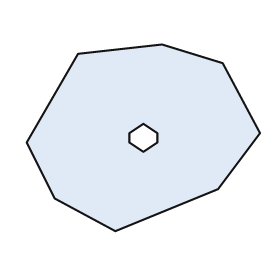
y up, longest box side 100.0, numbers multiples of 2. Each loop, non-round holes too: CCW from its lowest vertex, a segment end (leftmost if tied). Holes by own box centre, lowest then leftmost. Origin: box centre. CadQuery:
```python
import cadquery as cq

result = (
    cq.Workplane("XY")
    .moveTo(-12.0, -40.0)
    .lineTo(32.0, -22.0)
    .lineTo(50.0, 2.0)
    .lineTo(34.0, 32.0)
    .lineTo(8.0, 40.0)
    .lineTo(-28.0, 36.0)
    .lineTo(-50.0, -2.0)
    .lineTo(-38.0, -26.0)
    .close()
    .moveTo(0.0, -6.0)
    .lineTo(6.0, -2.0)
    .lineTo(6.0, 2.0)
    .lineTo(0.0, 6.0)
    .lineTo(-6.0, 2.0)
    .lineTo(-6.0, -2.0)
    .close()
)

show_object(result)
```